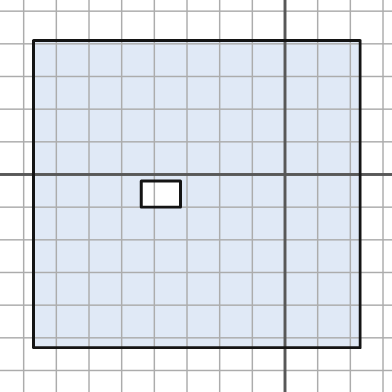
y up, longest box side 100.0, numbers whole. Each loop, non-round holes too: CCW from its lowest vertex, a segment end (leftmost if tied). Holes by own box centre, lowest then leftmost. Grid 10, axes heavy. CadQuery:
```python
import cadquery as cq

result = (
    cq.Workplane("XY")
    .moveTo(-77.0, -53.0)
    .lineTo(23.0, -53.0)
    .lineTo(23.0, 41.0)
    .lineTo(-77.0, 41.0)
    .close()
    .moveTo(-44.0, -10.0)
    .lineTo(-32.0, -10.0)
    .lineTo(-32.0, -2.0)
    .lineTo(-44.0, -2.0)
    .close()
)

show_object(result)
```